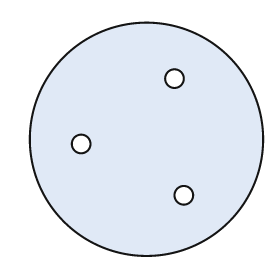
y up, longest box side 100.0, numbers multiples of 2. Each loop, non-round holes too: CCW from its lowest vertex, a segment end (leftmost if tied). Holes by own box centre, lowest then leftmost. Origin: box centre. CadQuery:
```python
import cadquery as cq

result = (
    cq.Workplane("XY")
    .moveTo(0.0, 0.0)
    .circle(50.0)
    .moveTo(16.0, -24.0)
    .circle(4.0)
    .moveTo(-28.0, -2.0)
    .circle(4.0)
    .moveTo(12.0, 26.0)
    .circle(4.0)
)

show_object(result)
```